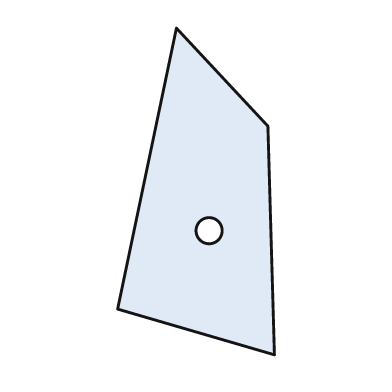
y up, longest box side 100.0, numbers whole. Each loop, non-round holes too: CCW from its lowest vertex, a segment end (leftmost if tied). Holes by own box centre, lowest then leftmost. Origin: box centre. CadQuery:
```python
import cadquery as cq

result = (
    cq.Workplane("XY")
    .moveTo(24.0, -50.0)
    .lineTo(22.0, 20.0)
    .lineTo(-6.0, 50.0)
    .lineTo(-24.0, -36.0)
    .close()
    .moveTo(4.0, -12.0)
    .circle(4.0)
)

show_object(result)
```